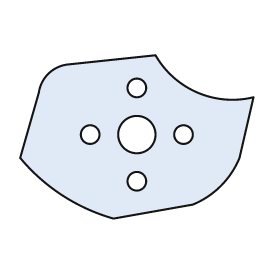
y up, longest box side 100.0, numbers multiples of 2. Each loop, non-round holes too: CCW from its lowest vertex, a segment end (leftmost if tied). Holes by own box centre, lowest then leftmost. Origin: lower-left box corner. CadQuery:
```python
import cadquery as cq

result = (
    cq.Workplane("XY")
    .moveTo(40.0, 0.0)
    .lineTo(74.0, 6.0)
    .threePointArc((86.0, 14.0), (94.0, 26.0))
    .lineTo(100.0, 52.0)
    .threePointArc((76.0, 54.0), (58.0, 70.0))
    .lineTo(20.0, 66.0)
    .threePointArc((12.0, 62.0), (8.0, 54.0))
    .lineTo(0.0, 26.0)
    .threePointArc((18.0, 10.0), (40.0, 0.0))
    .close()
    .moveTo(50.0, 16.0)
    .circle(4.0)
    .moveTo(30.0, 36.0)
    .circle(4.0)
    .moveTo(50.0, 36.0)
    .circle(8.0)
    .moveTo(70.0, 36.0)
    .circle(4.0)
    .moveTo(50.0, 56.0)
    .circle(4.0)
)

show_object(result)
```